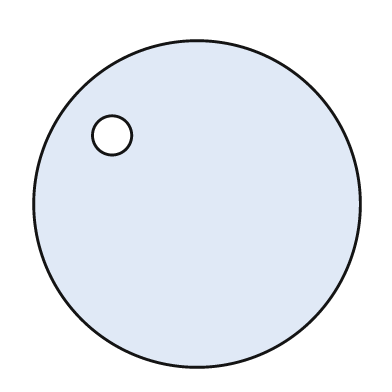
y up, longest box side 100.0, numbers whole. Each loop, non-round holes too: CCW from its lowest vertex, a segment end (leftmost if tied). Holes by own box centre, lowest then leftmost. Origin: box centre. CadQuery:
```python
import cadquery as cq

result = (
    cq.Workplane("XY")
    .moveTo(0.0, 0.0)
    .circle(50.0)
    .moveTo(-26.0, 21.0)
    .circle(6.0)
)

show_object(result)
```